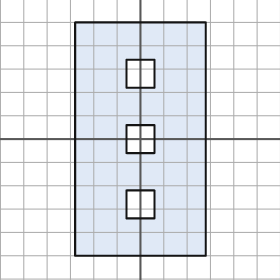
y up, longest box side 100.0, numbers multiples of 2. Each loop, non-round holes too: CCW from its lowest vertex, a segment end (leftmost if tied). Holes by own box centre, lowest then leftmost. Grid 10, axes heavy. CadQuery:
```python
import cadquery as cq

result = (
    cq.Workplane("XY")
    .moveTo(-28.0, -50.0)
    .lineTo(28.0, -50.0)
    .lineTo(28.0, 50.0)
    .lineTo(-28.0, 50.0)
    .close()
    .moveTo(-6.0, -34.0)
    .lineTo(6.0, -34.0)
    .lineTo(6.0, -22.0)
    .lineTo(-6.0, -22.0)
    .close()
    .moveTo(-6.0, -6.0)
    .lineTo(6.0, -6.0)
    .lineTo(6.0, 6.0)
    .lineTo(-6.0, 6.0)
    .close()
    .moveTo(-6.0, 22.0)
    .lineTo(6.0, 22.0)
    .lineTo(6.0, 34.0)
    .lineTo(-6.0, 34.0)
    .close()
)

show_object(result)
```